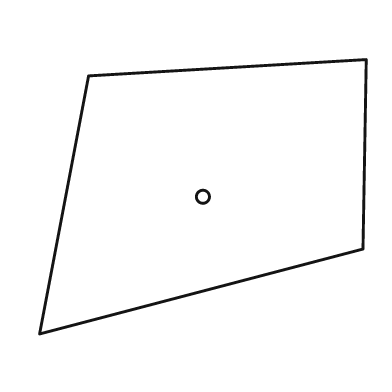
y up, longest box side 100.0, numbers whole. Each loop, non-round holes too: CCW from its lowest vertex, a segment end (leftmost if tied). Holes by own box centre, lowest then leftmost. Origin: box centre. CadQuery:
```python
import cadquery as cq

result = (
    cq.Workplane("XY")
    .moveTo(-50.0, -42.0)
    .lineTo(49.0, -16.0)
    .lineTo(50.0, 42.0)
    .lineTo(-35.0, 37.0)
    .close()
    .moveTo(0.0, 0.0)
    .circle(2.0)
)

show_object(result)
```